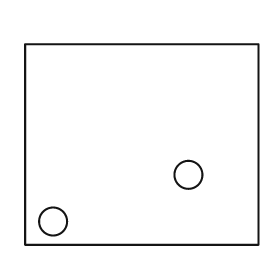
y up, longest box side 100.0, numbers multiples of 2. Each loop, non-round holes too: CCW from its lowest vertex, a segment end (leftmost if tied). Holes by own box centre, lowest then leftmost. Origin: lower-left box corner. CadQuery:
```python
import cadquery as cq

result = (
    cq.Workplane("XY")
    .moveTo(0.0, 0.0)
    .lineTo(100.0, 0.0)
    .lineTo(100.0, 86.0)
    .lineTo(0.0, 86.0)
    .close()
    .moveTo(12.0, 10.0)
    .circle(6.0)
    .moveTo(70.0, 30.0)
    .circle(6.0)
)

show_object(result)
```